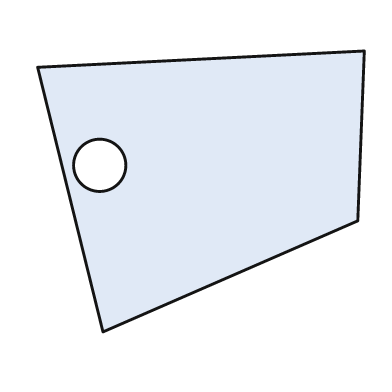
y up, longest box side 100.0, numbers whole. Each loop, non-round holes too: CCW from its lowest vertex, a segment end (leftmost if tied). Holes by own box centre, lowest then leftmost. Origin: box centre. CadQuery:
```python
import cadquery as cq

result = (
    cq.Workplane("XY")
    .moveTo(-30.0, -43.0)
    .lineTo(48.0, -9.0)
    .lineTo(50.0, 43.0)
    .lineTo(-50.0, 38.0)
    .close()
    .moveTo(-31.0, 8.0)
    .circle(8.0)
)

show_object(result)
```